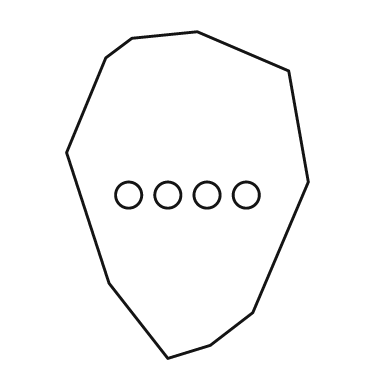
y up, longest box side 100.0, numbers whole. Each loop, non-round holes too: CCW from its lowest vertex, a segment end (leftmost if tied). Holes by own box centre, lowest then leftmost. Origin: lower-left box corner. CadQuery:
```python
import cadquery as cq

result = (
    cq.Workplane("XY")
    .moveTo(31.0, 0.0)
    .lineTo(44.0, 4.0)
    .lineTo(57.0, 14.0)
    .lineTo(74.0, 54.0)
    .lineTo(68.0, 88.0)
    .lineTo(40.0, 100.0)
    .lineTo(20.0, 98.0)
    .lineTo(12.0, 92.0)
    .lineTo(0.0, 63.0)
    .lineTo(13.0, 23.0)
    .close()
    .moveTo(19.0, 50.0)
    .circle(4.0)
    .moveTo(31.0, 50.0)
    .circle(4.0)
    .moveTo(43.0, 50.0)
    .circle(4.0)
    .moveTo(55.0, 50.0)
    .circle(4.0)
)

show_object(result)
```